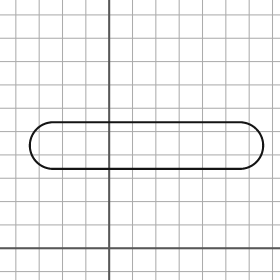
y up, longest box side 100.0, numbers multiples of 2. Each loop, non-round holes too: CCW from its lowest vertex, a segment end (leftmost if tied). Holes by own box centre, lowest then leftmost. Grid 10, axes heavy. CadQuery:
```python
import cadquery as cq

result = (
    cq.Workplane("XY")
    .moveTo(-24.0, 34.0)
    .lineTo(56.0, 34.0)
    .threePointArc((66.0, 44.0), (56.0, 54.0))
    .lineTo(-24.0, 54.0)
    .threePointArc((-34.0, 44.0), (-24.0, 34.0))
    .close()
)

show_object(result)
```